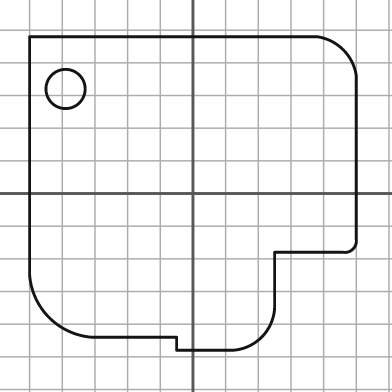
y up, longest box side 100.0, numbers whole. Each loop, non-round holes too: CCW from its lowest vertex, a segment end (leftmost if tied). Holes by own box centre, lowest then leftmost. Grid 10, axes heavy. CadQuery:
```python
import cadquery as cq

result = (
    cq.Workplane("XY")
    .moveTo(-5.0, -48.0)
    .lineTo(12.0, -48.0)
    .threePointArc((21.0, -44.0), (25.0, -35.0))
    .lineTo(25.0, -18.0)
    .lineTo(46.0, -18.0)
    .threePointArc((49.0, -17.0), (50.0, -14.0))
    .lineTo(50.0, 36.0)
    .threePointArc((46.0, 44.0), (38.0, 48.0))
    .lineTo(-50.0, 48.0)
    .lineTo(-50.0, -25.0)
    .threePointArc((-44.0, -38.0), (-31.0, -44.0))
    .lineTo(-5.0, -44.0)
    .close()
    .moveTo(-39.0, 32.0)
    .circle(6.0)
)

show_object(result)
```